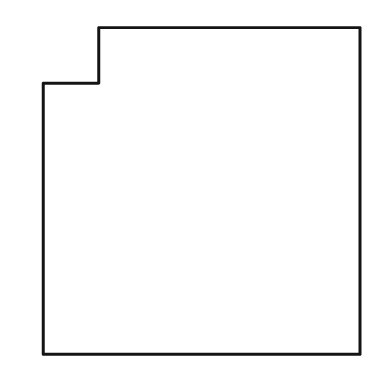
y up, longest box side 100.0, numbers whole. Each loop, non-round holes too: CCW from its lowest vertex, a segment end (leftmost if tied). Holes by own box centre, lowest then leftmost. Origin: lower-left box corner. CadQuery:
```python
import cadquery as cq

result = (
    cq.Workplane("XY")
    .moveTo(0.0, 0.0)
    .lineTo(97.0, 0.0)
    .lineTo(97.0, 100.0)
    .lineTo(17.0, 100.0)
    .lineTo(17.0, 83.0)
    .lineTo(0.0, 83.0)
    .close()
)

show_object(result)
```